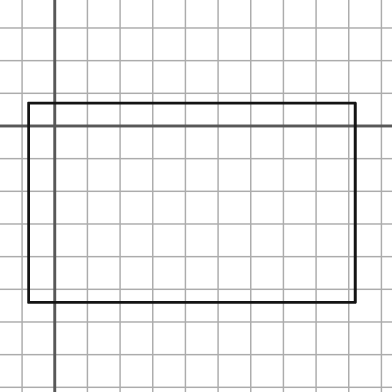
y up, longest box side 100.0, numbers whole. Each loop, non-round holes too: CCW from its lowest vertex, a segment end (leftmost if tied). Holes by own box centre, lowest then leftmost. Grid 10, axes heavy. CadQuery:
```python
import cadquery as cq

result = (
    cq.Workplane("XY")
    .moveTo(-8.0, -54.0)
    .lineTo(92.0, -54.0)
    .lineTo(92.0, 7.0)
    .lineTo(-8.0, 7.0)
    .close()
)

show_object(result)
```